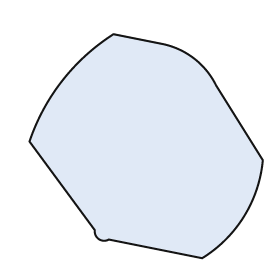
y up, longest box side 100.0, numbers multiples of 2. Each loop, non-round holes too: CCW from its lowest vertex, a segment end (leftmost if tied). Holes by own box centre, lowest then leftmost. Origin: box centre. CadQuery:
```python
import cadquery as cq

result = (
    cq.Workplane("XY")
    .moveTo(24.0, -48.0)
    .threePointArc((42.0, -30.0), (50.0, -6.0))
    .lineTo(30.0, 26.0)
    .threePointArc((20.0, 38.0), (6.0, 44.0))
    .lineTo(-14.0, 48.0)
    .threePointArc((-36.0, 28.0), (-50.0, 2.0))
    .lineTo(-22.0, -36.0)
    .threePointArc((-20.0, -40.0), (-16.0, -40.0))
    .close()
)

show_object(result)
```